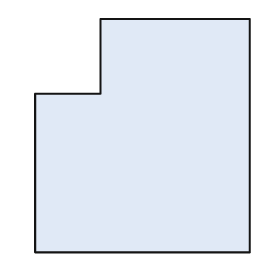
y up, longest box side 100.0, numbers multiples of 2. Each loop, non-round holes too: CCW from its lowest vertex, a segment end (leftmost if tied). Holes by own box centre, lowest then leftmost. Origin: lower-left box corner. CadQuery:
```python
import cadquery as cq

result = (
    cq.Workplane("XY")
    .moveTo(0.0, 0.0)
    .lineTo(92.0, 0.0)
    .lineTo(92.0, 100.0)
    .lineTo(28.0, 100.0)
    .lineTo(28.0, 68.0)
    .lineTo(0.0, 68.0)
    .close()
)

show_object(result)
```